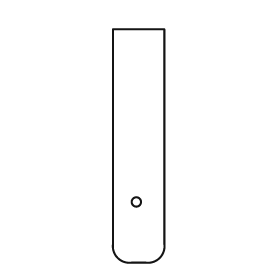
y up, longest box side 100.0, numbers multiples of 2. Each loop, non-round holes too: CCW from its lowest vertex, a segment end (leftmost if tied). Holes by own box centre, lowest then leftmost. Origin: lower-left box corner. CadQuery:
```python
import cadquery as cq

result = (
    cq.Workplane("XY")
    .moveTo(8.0, 0.0)
    .lineTo(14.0, 0.0)
    .threePointArc((20.0, 2.0), (22.0, 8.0))
    .lineTo(22.0, 100.0)
    .lineTo(0.0, 100.0)
    .lineTo(0.0, 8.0)
    .threePointArc((2.0, 2.0), (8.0, 0.0))
    .close()
    .moveTo(10.0, 26.0)
    .circle(2.0)
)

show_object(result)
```